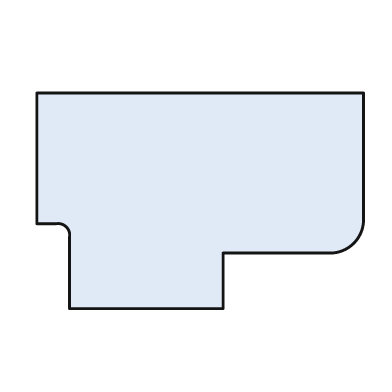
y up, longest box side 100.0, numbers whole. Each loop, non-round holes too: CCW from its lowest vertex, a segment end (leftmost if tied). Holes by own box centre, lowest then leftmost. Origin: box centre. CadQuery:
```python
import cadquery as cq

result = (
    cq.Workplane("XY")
    .moveTo(-40.0, -33.0)
    .lineTo(7.0, -33.0)
    .lineTo(7.0, -16.0)
    .lineTo(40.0, -16.0)
    .threePointArc((47.0, -13.0), (50.0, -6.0))
    .lineTo(50.0, 33.0)
    .lineTo(-50.0, 33.0)
    .lineTo(-50.0, -7.0)
    .lineTo(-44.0, -7.0)
    .threePointArc((-41.0, -8.0), (-40.0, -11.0))
    .close()
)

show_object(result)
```